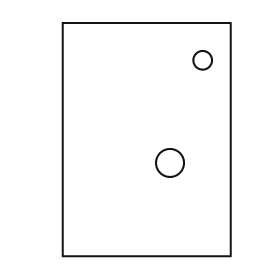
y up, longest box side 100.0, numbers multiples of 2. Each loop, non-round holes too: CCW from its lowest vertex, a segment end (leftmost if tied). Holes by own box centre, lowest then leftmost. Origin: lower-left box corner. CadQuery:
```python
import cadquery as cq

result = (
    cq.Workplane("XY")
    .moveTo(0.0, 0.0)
    .lineTo(72.0, 0.0)
    .lineTo(72.0, 100.0)
    .lineTo(0.0, 100.0)
    .close()
    .moveTo(46.0, 40.0)
    .circle(6.0)
    .moveTo(60.0, 84.0)
    .circle(4.0)
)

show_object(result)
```